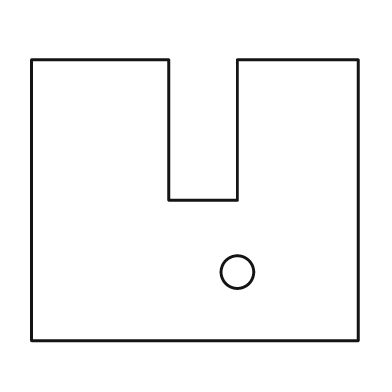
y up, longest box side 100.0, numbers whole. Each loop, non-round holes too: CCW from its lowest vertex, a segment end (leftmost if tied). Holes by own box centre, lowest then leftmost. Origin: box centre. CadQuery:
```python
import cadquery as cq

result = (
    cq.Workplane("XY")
    .moveTo(-50.0, -43.0)
    .lineTo(50.0, -43.0)
    .lineTo(50.0, 43.0)
    .lineTo(13.0, 43.0)
    .lineTo(13.0, 0.0)
    .lineTo(-8.0, 0.0)
    .lineTo(-8.0, 43.0)
    .lineTo(-50.0, 43.0)
    .close()
    .moveTo(13.0, -22.0)
    .circle(5.0)
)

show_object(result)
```